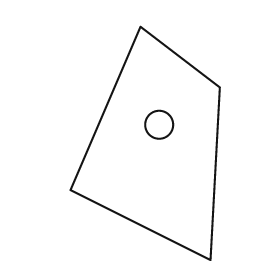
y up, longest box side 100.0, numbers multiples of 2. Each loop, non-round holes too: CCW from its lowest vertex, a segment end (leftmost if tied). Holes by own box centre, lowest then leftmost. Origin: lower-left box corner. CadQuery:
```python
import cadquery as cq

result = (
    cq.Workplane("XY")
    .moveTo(60.0, 0.0)
    .lineTo(64.0, 74.0)
    .lineTo(30.0, 100.0)
    .lineTo(0.0, 30.0)
    .close()
    .moveTo(38.0, 58.0)
    .circle(6.0)
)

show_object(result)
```